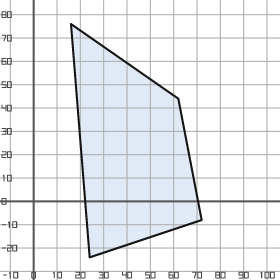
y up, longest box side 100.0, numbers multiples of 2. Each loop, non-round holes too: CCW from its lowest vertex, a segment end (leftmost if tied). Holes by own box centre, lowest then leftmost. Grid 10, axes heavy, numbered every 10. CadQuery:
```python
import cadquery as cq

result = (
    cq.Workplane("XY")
    .moveTo(24.0, -24.0)
    .lineTo(72.0, -8.0)
    .lineTo(62.0, 44.0)
    .lineTo(16.0, 76.0)
    .close()
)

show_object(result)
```